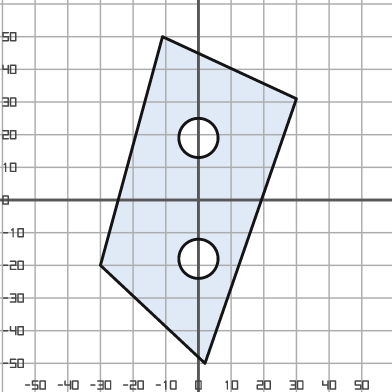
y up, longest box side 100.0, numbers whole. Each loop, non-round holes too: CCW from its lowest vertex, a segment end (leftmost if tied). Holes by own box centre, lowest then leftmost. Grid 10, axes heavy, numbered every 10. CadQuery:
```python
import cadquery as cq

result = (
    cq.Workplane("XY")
    .moveTo(2.0, -50.0)
    .lineTo(30.0, 31.0)
    .lineTo(-11.0, 50.0)
    .lineTo(-30.0, -20.0)
    .close()
    .moveTo(0.0, -18.0)
    .circle(6.0)
    .moveTo(0.0, 19.0)
    .circle(6.0)
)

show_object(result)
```